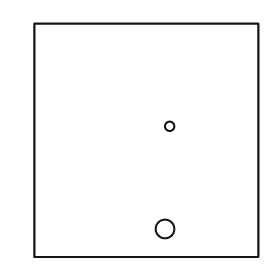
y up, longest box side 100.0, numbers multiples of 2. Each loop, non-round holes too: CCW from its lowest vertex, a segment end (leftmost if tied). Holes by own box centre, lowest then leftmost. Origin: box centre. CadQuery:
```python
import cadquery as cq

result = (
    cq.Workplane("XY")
    .moveTo(-48.0, -50.0)
    .lineTo(48.0, -50.0)
    .lineTo(48.0, 50.0)
    .lineTo(-48.0, 50.0)
    .close()
    .moveTo(8.0, -38.0)
    .circle(4.0)
    .moveTo(10.0, 6.0)
    .circle(2.0)
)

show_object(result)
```